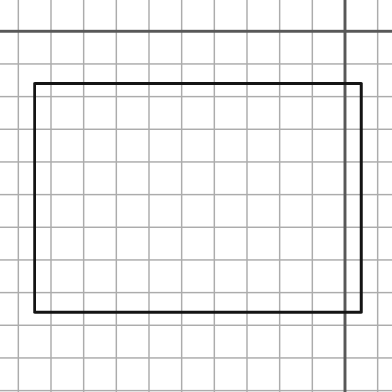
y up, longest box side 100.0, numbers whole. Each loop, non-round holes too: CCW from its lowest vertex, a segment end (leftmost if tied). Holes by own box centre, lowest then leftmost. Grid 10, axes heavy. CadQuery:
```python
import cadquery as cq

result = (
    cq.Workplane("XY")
    .moveTo(-95.0, -86.0)
    .lineTo(5.0, -86.0)
    .lineTo(5.0, -16.0)
    .lineTo(-95.0, -16.0)
    .close()
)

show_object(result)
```